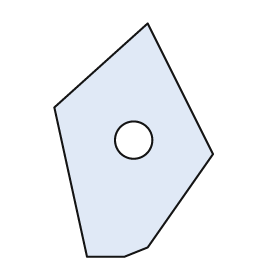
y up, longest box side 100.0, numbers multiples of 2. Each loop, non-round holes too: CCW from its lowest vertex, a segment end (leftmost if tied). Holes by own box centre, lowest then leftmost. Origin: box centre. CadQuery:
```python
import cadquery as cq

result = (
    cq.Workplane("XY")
    .moveTo(-20.0, -50.0)
    .lineTo(-4.0, -50.0)
    .lineTo(6.0, -46.0)
    .lineTo(34.0, -6.0)
    .lineTo(6.0, 50.0)
    .lineTo(-34.0, 14.0)
    .close()
    .moveTo(0.0, 0.0)
    .circle(8.0)
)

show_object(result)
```